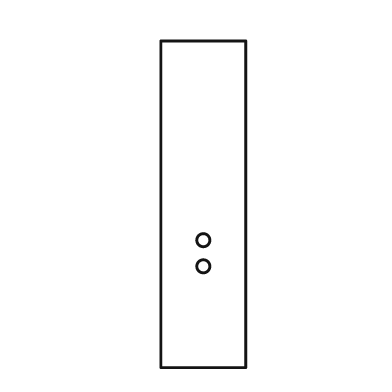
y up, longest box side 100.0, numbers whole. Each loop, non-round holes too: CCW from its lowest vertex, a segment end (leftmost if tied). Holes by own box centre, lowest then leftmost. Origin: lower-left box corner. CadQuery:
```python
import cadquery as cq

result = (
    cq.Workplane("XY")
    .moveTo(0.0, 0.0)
    .lineTo(26.0, 0.0)
    .lineTo(26.0, 100.0)
    .lineTo(0.0, 100.0)
    .close()
    .moveTo(13.0, 31.0)
    .circle(2.0)
    .moveTo(13.0, 39.0)
    .circle(2.0)
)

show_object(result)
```